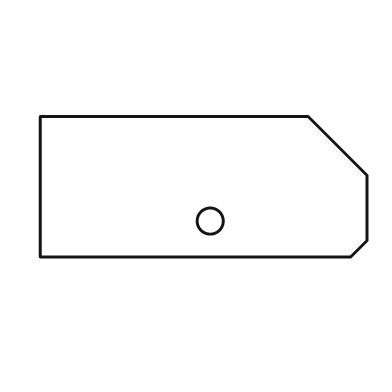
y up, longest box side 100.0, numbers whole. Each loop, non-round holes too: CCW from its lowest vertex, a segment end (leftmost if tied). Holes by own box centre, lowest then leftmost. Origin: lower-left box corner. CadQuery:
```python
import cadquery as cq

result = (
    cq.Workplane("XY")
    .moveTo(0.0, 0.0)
    .lineTo(95.0, 0.0)
    .lineTo(100.0, 5.0)
    .lineTo(100.0, 25.0)
    .lineTo(82.0, 43.0)
    .lineTo(0.0, 43.0)
    .close()
    .moveTo(52.0, 11.0)
    .circle(4.0)
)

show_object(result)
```